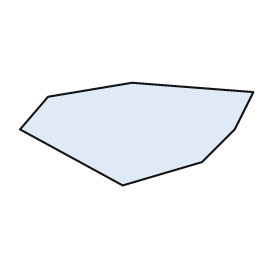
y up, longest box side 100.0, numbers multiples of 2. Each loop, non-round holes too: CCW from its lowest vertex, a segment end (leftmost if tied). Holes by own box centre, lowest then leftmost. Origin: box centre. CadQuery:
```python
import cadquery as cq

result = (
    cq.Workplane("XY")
    .moveTo(-6.0, -22.0)
    .lineTo(28.0, -12.0)
    .lineTo(42.0, 2.0)
    .lineTo(50.0, 18.0)
    .lineTo(-2.0, 22.0)
    .lineTo(-38.0, 16.0)
    .lineTo(-50.0, 2.0)
    .close()
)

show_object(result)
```